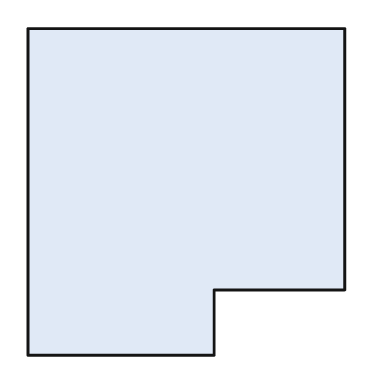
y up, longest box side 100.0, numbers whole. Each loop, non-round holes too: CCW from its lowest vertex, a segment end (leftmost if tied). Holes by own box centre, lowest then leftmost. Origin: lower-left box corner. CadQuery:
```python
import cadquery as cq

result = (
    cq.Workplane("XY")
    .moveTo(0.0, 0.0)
    .lineTo(57.0, 0.0)
    .lineTo(57.0, 20.0)
    .lineTo(97.0, 20.0)
    .lineTo(97.0, 100.0)
    .lineTo(0.0, 100.0)
    .close()
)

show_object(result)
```